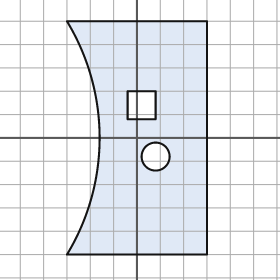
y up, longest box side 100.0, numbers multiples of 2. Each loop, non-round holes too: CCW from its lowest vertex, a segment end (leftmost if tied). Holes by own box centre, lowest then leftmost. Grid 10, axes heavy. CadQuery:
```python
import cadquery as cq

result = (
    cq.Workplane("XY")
    .moveTo(-30.0, -50.0)
    .lineTo(30.0, -50.0)
    .lineTo(30.0, 50.0)
    .lineTo(-30.0, 50.0)
    .threePointArc((-16.0, 0.0), (-30.0, -50.0))
    .close()
    .moveTo(8.0, -8.0)
    .circle(6.0)
    .moveTo(-4.0, 8.0)
    .lineTo(8.0, 8.0)
    .lineTo(8.0, 20.0)
    .lineTo(-4.0, 20.0)
    .close()
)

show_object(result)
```